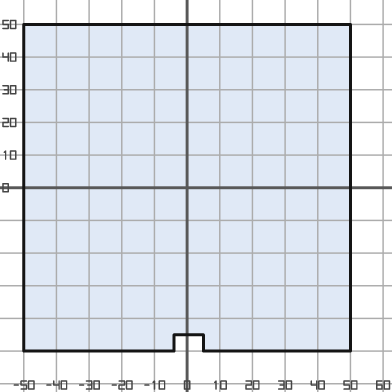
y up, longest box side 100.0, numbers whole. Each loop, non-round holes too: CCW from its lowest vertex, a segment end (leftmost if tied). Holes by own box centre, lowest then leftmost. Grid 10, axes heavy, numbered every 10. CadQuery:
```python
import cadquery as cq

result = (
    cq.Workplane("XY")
    .moveTo(-50.0, -50.0)
    .lineTo(-4.0, -50.0)
    .lineTo(-4.0, -45.0)
    .lineTo(5.0, -45.0)
    .lineTo(5.0, -50.0)
    .lineTo(50.0, -50.0)
    .lineTo(50.0, 50.0)
    .lineTo(-50.0, 50.0)
    .close()
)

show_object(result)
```